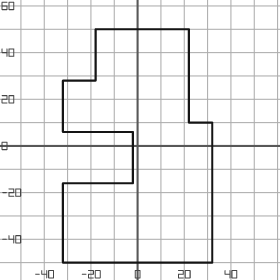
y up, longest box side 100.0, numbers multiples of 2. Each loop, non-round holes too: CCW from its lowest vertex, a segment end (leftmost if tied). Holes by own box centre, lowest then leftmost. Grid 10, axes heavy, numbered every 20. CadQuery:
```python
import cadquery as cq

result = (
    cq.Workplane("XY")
    .moveTo(-32.0, -50.0)
    .lineTo(32.0, -50.0)
    .lineTo(32.0, 10.0)
    .lineTo(22.0, 10.0)
    .lineTo(22.0, 50.0)
    .lineTo(-18.0, 50.0)
    .lineTo(-18.0, 28.0)
    .lineTo(-32.0, 28.0)
    .lineTo(-32.0, 6.0)
    .lineTo(-2.0, 6.0)
    .lineTo(-2.0, -16.0)
    .lineTo(-32.0, -16.0)
    .close()
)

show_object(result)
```